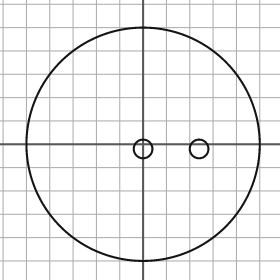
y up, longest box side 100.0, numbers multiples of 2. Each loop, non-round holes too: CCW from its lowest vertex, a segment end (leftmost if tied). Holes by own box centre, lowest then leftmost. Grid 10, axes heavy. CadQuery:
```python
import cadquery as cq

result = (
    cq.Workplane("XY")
    .moveTo(0.0, 0.0)
    .circle(50.0)
    .moveTo(0.0, -2.0)
    .circle(4.0)
    .moveTo(24.0, -2.0)
    .circle(4.0)
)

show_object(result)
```